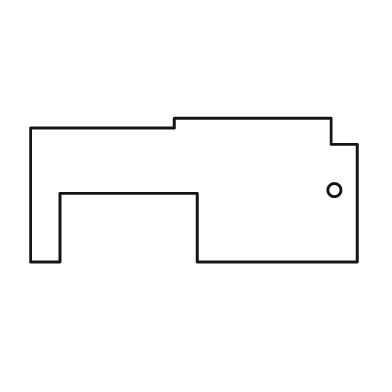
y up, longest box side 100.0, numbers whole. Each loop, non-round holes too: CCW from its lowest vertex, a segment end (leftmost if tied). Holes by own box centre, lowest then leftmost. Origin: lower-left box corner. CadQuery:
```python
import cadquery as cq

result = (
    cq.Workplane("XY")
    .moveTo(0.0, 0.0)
    .lineTo(9.0, 0.0)
    .lineTo(9.0, 21.0)
    .lineTo(51.0, 21.0)
    .lineTo(51.0, 0.0)
    .lineTo(100.0, 0.0)
    .lineTo(100.0, 36.0)
    .lineTo(92.0, 36.0)
    .lineTo(92.0, 44.0)
    .lineTo(44.0, 44.0)
    .lineTo(44.0, 41.0)
    .lineTo(0.0, 41.0)
    .close()
    .moveTo(93.0, 22.0)
    .circle(2.0)
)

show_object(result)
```